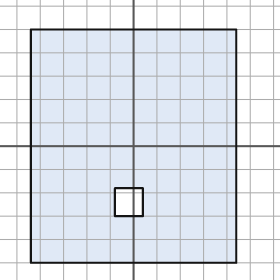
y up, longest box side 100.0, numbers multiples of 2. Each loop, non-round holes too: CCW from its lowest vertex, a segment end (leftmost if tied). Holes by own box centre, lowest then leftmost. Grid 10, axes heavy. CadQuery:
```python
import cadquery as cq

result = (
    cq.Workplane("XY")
    .moveTo(-44.0, -50.0)
    .lineTo(44.0, -50.0)
    .lineTo(44.0, 50.0)
    .lineTo(-44.0, 50.0)
    .close()
    .moveTo(-8.0, -30.0)
    .lineTo(4.0, -30.0)
    .lineTo(4.0, -18.0)
    .lineTo(-8.0, -18.0)
    .close()
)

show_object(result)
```